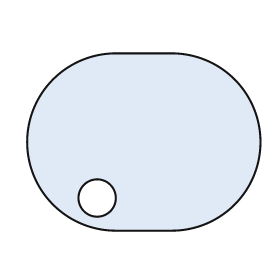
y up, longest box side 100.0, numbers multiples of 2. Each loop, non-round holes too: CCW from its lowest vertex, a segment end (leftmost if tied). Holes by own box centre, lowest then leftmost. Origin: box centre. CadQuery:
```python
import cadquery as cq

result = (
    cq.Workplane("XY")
    .moveTo(-12.0, -38.0)
    .lineTo(12.0, -38.0)
    .threePointArc((50.0, 0.0), (12.0, 38.0))
    .lineTo(-12.0, 38.0)
    .threePointArc((-50.0, 0.0), (-12.0, -38.0))
    .close()
    .moveTo(-20.0, -24.0)
    .circle(8.0)
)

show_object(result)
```